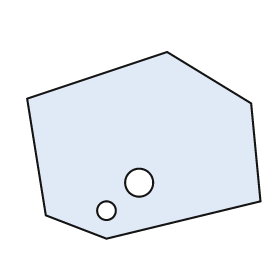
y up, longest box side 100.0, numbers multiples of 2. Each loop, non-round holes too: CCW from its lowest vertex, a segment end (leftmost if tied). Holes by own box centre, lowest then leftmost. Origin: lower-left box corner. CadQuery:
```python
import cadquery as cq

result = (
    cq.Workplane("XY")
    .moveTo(34.0, 0.0)
    .lineTo(100.0, 16.0)
    .lineTo(96.0, 58.0)
    .lineTo(60.0, 80.0)
    .lineTo(0.0, 60.0)
    .lineTo(8.0, 10.0)
    .close()
    .moveTo(34.0, 12.0)
    .circle(4.0)
    .moveTo(48.0, 24.0)
    .circle(6.0)
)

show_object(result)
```